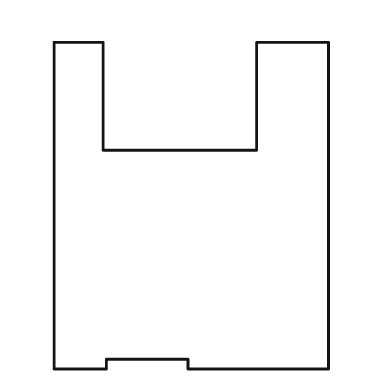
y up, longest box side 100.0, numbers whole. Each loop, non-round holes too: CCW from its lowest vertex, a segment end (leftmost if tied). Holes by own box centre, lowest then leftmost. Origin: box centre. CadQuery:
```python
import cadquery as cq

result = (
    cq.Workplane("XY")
    .moveTo(-42.0, -50.0)
    .lineTo(-26.0, -50.0)
    .lineTo(-26.0, -47.0)
    .lineTo(-1.0, -47.0)
    .lineTo(-1.0, -50.0)
    .lineTo(42.0, -50.0)
    .lineTo(42.0, 50.0)
    .lineTo(20.0, 50.0)
    .lineTo(20.0, 17.0)
    .lineTo(-27.0, 17.0)
    .lineTo(-27.0, 50.0)
    .lineTo(-42.0, 50.0)
    .close()
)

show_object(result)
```